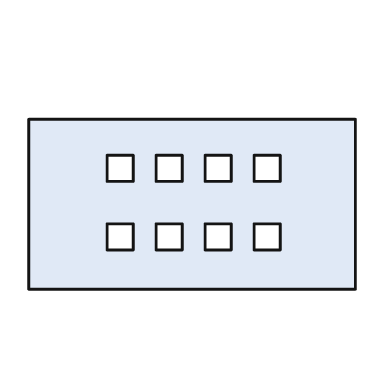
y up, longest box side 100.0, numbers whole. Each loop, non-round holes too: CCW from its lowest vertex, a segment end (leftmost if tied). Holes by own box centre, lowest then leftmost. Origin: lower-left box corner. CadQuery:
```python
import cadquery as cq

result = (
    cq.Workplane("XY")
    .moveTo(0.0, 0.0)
    .lineTo(100.0, 0.0)
    .lineTo(100.0, 52.0)
    .lineTo(0.0, 52.0)
    .close()
    .moveTo(24.0, 12.0)
    .lineTo(32.0, 12.0)
    .lineTo(32.0, 20.0)
    .lineTo(24.0, 20.0)
    .close()
    .moveTo(39.0, 12.0)
    .lineTo(47.0, 12.0)
    .lineTo(47.0, 20.0)
    .lineTo(39.0, 20.0)
    .close()
    .moveTo(54.0, 12.0)
    .lineTo(62.0, 12.0)
    .lineTo(62.0, 20.0)
    .lineTo(54.0, 20.0)
    .close()
    .moveTo(69.0, 12.0)
    .lineTo(77.0, 12.0)
    .lineTo(77.0, 20.0)
    .lineTo(69.0, 20.0)
    .close()
    .moveTo(24.0, 33.0)
    .lineTo(32.0, 33.0)
    .lineTo(32.0, 41.0)
    .lineTo(24.0, 41.0)
    .close()
    .moveTo(39.0, 33.0)
    .lineTo(47.0, 33.0)
    .lineTo(47.0, 41.0)
    .lineTo(39.0, 41.0)
    .close()
    .moveTo(54.0, 33.0)
    .lineTo(62.0, 33.0)
    .lineTo(62.0, 41.0)
    .lineTo(54.0, 41.0)
    .close()
    .moveTo(69.0, 33.0)
    .lineTo(77.0, 33.0)
    .lineTo(77.0, 41.0)
    .lineTo(69.0, 41.0)
    .close()
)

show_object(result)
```